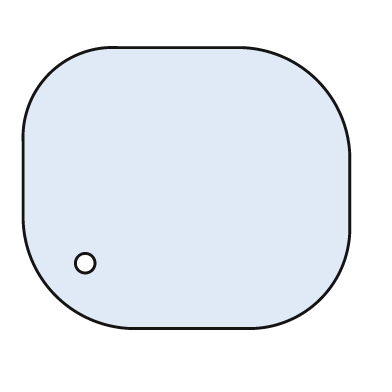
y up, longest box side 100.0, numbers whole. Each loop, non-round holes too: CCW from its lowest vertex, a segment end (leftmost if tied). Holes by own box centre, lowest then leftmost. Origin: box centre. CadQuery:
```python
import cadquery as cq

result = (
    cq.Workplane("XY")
    .moveTo(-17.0, -43.0)
    .lineTo(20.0, -43.0)
    .threePointArc((41.0, -34.0), (50.0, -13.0))
    .lineTo(50.0, 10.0)
    .threePointArc((40.0, 33.0), (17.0, 43.0))
    .lineTo(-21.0, 43.0)
    .threePointArc((-42.0, 35.0), (-50.0, 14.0))
    .lineTo(-50.0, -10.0)
    .threePointArc((-40.0, -33.0), (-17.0, -43.0))
    .close()
    .moveTo(-31.0, -23.0)
    .circle(3.0)
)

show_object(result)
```